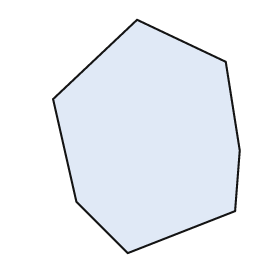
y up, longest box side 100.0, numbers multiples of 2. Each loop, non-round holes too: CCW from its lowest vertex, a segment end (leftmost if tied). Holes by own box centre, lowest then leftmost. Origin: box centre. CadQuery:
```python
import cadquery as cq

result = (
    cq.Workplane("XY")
    .moveTo(-8.0, -50.0)
    .lineTo(38.0, -32.0)
    .lineTo(40.0, -6.0)
    .lineTo(34.0, 32.0)
    .lineTo(-4.0, 50.0)
    .lineTo(-40.0, 16.0)
    .lineTo(-30.0, -28.0)
    .close()
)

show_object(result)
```